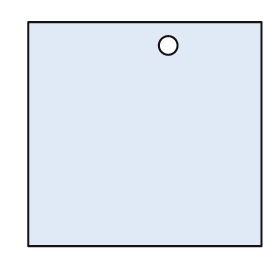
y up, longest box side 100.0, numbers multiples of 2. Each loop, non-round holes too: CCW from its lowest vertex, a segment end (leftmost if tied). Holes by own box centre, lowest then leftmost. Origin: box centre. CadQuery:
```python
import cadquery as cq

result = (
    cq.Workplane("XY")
    .moveTo(-50.0, -48.0)
    .lineTo(50.0, -48.0)
    .lineTo(50.0, 48.0)
    .lineTo(-50.0, 48.0)
    .close()
    .moveTo(10.0, 38.0)
    .circle(4.0)
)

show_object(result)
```